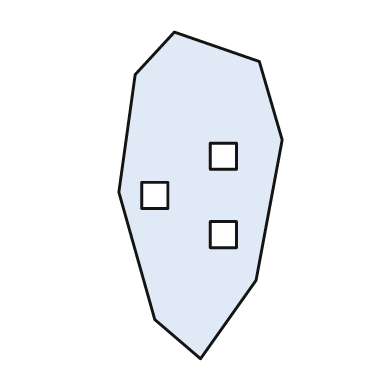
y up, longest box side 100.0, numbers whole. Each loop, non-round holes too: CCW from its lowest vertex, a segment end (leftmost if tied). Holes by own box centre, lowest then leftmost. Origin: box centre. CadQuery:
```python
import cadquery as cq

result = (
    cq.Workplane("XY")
    .moveTo(0.0, -50.0)
    .lineTo(17.0, -26.0)
    .lineTo(25.0, 17.0)
    .lineTo(18.0, 41.0)
    .lineTo(-8.0, 50.0)
    .lineTo(-20.0, 37.0)
    .lineTo(-25.0, 1.0)
    .lineTo(-14.0, -38.0)
    .close()
    .moveTo(3.0, -16.0)
    .lineTo(11.0, -16.0)
    .lineTo(11.0, -8.0)
    .lineTo(3.0, -8.0)
    .close()
    .moveTo(-18.0, -4.0)
    .lineTo(-10.0, -4.0)
    .lineTo(-10.0, 4.0)
    .lineTo(-18.0, 4.0)
    .close()
    .moveTo(3.0, 8.0)
    .lineTo(11.0, 8.0)
    .lineTo(11.0, 16.0)
    .lineTo(3.0, 16.0)
    .close()
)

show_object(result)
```